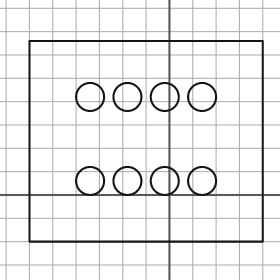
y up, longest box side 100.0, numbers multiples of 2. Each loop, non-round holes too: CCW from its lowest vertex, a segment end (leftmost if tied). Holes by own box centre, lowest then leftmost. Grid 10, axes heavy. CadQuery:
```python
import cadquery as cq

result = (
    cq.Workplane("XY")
    .moveTo(-60.0, -20.0)
    .lineTo(40.0, -20.0)
    .lineTo(40.0, 66.0)
    .lineTo(-60.0, 66.0)
    .close()
    .moveTo(-34.0, 6.0)
    .circle(6.0)
    .moveTo(-18.0, 6.0)
    .circle(6.0)
    .moveTo(-2.0, 6.0)
    .circle(6.0)
    .moveTo(14.0, 6.0)
    .circle(6.0)
    .moveTo(-34.0, 42.0)
    .circle(6.0)
    .moveTo(-18.0, 42.0)
    .circle(6.0)
    .moveTo(-2.0, 42.0)
    .circle(6.0)
    .moveTo(14.0, 42.0)
    .circle(6.0)
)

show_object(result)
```